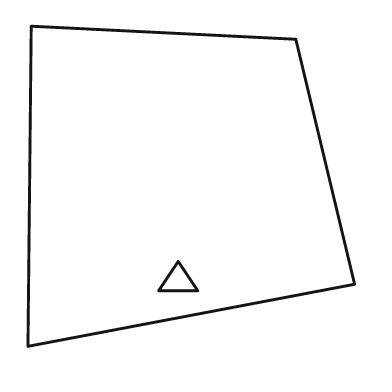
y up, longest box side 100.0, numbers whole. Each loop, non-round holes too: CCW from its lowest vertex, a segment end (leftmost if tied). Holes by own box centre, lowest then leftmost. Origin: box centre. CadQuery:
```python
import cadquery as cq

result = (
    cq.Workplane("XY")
    .moveTo(-50.0, -49.0)
    .lineTo(50.0, -30.0)
    .lineTo(32.0, 45.0)
    .lineTo(-49.0, 49.0)
    .close()
    .moveTo(-10.0, -32.0)
    .lineTo(2.0, -32.0)
    .lineTo(-4.0, -23.0)
    .close()
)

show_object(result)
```